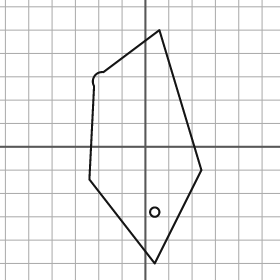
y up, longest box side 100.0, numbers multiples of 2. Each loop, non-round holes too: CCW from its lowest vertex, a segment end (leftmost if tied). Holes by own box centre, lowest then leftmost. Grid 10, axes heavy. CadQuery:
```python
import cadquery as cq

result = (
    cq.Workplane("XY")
    .moveTo(4.0, -50.0)
    .lineTo(24.0, -10.0)
    .lineTo(6.0, 50.0)
    .lineTo(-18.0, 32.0)
    .threePointArc((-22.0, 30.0), (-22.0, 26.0))
    .lineTo(-24.0, -14.0)
    .close()
    .moveTo(4.0, -28.0)
    .circle(2.0)
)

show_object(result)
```